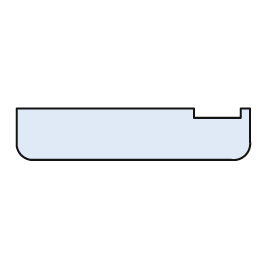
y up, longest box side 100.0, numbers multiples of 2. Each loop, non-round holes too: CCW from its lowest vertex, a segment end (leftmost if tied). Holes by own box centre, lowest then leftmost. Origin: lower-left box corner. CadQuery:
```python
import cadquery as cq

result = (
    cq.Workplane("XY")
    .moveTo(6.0, 0.0)
    .lineTo(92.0, 0.0)
    .threePointArc((98.0, 2.0), (100.0, 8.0))
    .lineTo(100.0, 22.0)
    .lineTo(96.0, 22.0)
    .lineTo(96.0, 18.0)
    .lineTo(76.0, 18.0)
    .lineTo(76.0, 22.0)
    .lineTo(0.0, 22.0)
    .lineTo(0.0, 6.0)
    .threePointArc((2.0, 2.0), (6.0, 0.0))
    .close()
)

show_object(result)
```